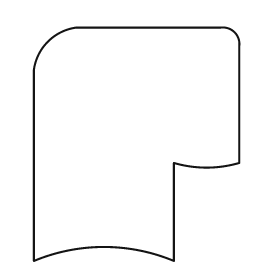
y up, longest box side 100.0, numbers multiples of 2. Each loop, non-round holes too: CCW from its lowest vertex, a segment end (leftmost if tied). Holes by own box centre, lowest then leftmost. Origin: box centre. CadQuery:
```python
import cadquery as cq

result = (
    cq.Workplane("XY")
    .moveTo(-44.0, -50.0)
    .threePointArc((-14.0, -44.0), (16.0, -50.0))
    .lineTo(16.0, -8.0)
    .threePointArc((30.0, -10.0), (44.0, -8.0))
    .lineTo(44.0, 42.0)
    .threePointArc((42.0, 48.0), (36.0, 50.0))
    .lineTo(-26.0, 50.0)
    .threePointArc((-38.0, 44.0), (-44.0, 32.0))
    .close()
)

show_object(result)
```